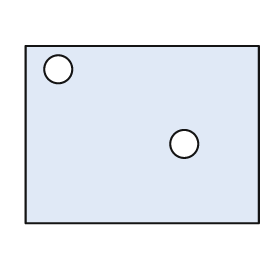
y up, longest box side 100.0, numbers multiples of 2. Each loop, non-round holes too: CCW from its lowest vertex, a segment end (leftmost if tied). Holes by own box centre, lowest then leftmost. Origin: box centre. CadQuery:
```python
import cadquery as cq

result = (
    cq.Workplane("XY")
    .moveTo(-50.0, -38.0)
    .lineTo(50.0, -38.0)
    .lineTo(50.0, 38.0)
    .lineTo(-50.0, 38.0)
    .close()
    .moveTo(18.0, -4.0)
    .circle(6.0)
    .moveTo(-36.0, 28.0)
    .circle(6.0)
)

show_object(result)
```